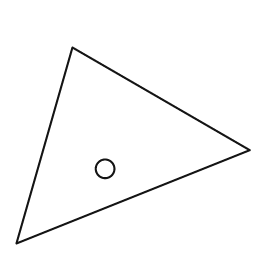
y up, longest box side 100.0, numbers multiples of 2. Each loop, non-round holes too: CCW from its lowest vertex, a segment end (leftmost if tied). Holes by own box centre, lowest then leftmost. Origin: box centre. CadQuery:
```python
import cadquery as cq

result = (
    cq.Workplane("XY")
    .moveTo(-50.0, -42.0)
    .lineTo(50.0, -2.0)
    .lineTo(-26.0, 42.0)
    .close()
    .moveTo(-12.0, -10.0)
    .circle(4.0)
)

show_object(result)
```